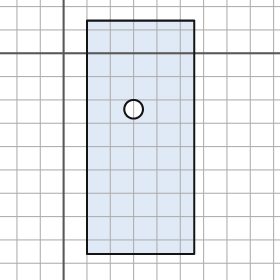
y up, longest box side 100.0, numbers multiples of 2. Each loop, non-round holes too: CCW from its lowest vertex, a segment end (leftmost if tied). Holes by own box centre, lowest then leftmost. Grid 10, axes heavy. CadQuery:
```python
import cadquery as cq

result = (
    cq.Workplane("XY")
    .moveTo(10.0, -86.0)
    .lineTo(56.0, -86.0)
    .lineTo(56.0, 14.0)
    .lineTo(10.0, 14.0)
    .close()
    .moveTo(30.0, -24.0)
    .circle(4.0)
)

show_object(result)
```